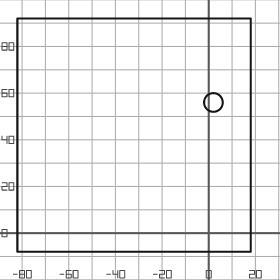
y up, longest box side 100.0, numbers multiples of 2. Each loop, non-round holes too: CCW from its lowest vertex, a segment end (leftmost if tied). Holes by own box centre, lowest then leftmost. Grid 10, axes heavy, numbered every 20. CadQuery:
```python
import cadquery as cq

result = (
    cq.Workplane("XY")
    .moveTo(-82.0, -8.0)
    .lineTo(18.0, -8.0)
    .lineTo(18.0, 92.0)
    .lineTo(-82.0, 92.0)
    .close()
    .moveTo(2.0, 56.0)
    .circle(4.0)
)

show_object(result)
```